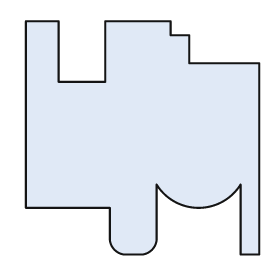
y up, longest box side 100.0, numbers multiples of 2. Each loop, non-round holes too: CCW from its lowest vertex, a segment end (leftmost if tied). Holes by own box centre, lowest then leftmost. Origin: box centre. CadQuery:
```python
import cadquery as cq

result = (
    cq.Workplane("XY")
    .moveTo(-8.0, -50.0)
    .lineTo(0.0, -50.0)
    .threePointArc((4.0, -48.0), (6.0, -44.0))
    .lineTo(6.0, -20.0)
    .threePointArc((24.0, -30.0), (42.0, -20.0))
    .lineTo(42.0, -50.0)
    .lineTo(50.0, -50.0)
    .lineTo(50.0, 32.0)
    .lineTo(20.0, 32.0)
    .lineTo(20.0, 44.0)
    .lineTo(12.0, 44.0)
    .lineTo(12.0, 50.0)
    .lineTo(-16.0, 50.0)
    .lineTo(-16.0, 24.0)
    .lineTo(-36.0, 24.0)
    .lineTo(-36.0, 50.0)
    .lineTo(-50.0, 50.0)
    .lineTo(-50.0, -30.0)
    .lineTo(-14.0, -30.0)
    .lineTo(-14.0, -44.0)
    .threePointArc((-12.0, -48.0), (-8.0, -50.0))
    .close()
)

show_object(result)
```